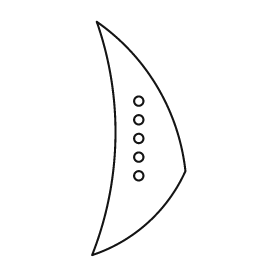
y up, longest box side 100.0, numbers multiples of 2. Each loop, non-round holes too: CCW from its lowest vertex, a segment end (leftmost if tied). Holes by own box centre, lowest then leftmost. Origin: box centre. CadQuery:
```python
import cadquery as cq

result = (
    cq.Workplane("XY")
    .moveTo(-20.0, -50.0)
    .threePointArc((4.0, -36.0), (20.0, -14.0))
    .threePointArc((8.0, 22.0), (-18.0, 50.0))
    .threePointArc((-10.0, 0.0), (-20.0, -50.0))
    .close()
    .moveTo(0.0, -16.0)
    .circle(2.0)
    .moveTo(0.0, -8.0)
    .circle(2.0)
    .moveTo(0.0, 0.0)
    .circle(2.0)
    .moveTo(0.0, 8.0)
    .circle(2.0)
    .moveTo(0.0, 16.0)
    .circle(2.0)
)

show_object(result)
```